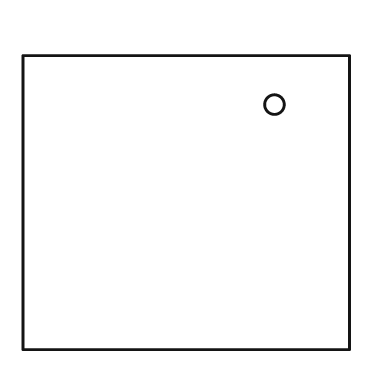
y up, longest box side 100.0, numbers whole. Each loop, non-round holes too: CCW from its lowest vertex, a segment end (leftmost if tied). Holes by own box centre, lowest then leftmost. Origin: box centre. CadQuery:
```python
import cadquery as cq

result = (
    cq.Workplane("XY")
    .moveTo(-50.0, -45.0)
    .lineTo(50.0, -45.0)
    .lineTo(50.0, 45.0)
    .lineTo(-50.0, 45.0)
    .close()
    .moveTo(27.0, 30.0)
    .circle(3.0)
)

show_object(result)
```